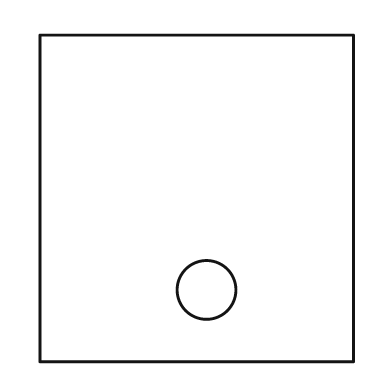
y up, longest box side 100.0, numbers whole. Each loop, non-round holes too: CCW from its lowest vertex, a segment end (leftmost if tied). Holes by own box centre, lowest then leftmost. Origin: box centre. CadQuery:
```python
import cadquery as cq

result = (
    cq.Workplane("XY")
    .moveTo(-48.0, -50.0)
    .lineTo(48.0, -50.0)
    .lineTo(48.0, 50.0)
    .lineTo(-48.0, 50.0)
    .close()
    .moveTo(3.0, -28.0)
    .circle(9.0)
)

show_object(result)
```